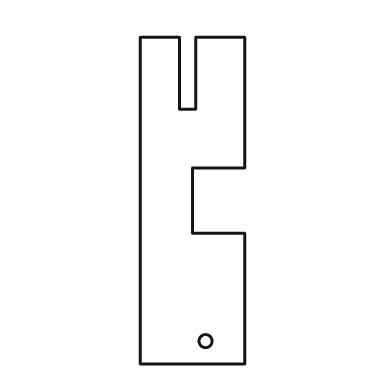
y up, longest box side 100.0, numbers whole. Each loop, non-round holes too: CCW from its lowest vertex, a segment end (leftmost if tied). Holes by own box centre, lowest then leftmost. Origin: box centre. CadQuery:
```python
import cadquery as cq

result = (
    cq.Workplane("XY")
    .moveTo(-16.0, -50.0)
    .lineTo(16.0, -50.0)
    .lineTo(16.0, -10.0)
    .lineTo(0.0, -10.0)
    .lineTo(0.0, 10.0)
    .lineTo(16.0, 10.0)
    .lineTo(16.0, 50.0)
    .lineTo(1.0, 50.0)
    .lineTo(1.0, 28.0)
    .lineTo(-4.0, 28.0)
    .lineTo(-4.0, 50.0)
    .lineTo(-16.0, 50.0)
    .close()
    .moveTo(4.0, -43.0)
    .circle(2.0)
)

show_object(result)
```